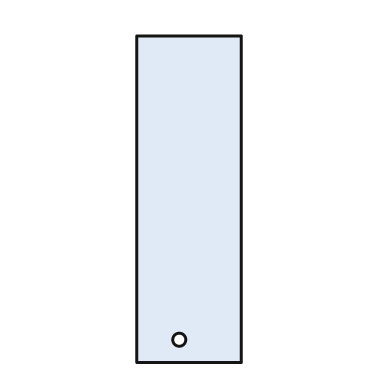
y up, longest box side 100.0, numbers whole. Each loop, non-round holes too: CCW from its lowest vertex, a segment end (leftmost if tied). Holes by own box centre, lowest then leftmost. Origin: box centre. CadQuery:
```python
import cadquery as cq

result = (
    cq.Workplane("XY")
    .moveTo(-16.0, -50.0)
    .lineTo(16.0, -50.0)
    .lineTo(16.0, 50.0)
    .lineTo(-16.0, 50.0)
    .close()
    .moveTo(-3.0, -43.0)
    .circle(2.0)
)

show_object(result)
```